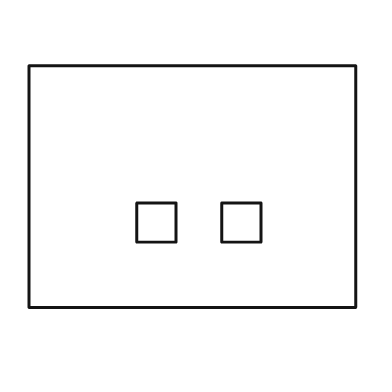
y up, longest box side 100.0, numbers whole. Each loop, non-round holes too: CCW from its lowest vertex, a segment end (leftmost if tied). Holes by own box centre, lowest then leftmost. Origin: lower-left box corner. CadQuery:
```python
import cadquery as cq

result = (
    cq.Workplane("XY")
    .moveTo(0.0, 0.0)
    .lineTo(100.0, 0.0)
    .lineTo(100.0, 74.0)
    .lineTo(0.0, 74.0)
    .close()
    .moveTo(33.0, 20.0)
    .lineTo(45.0, 20.0)
    .lineTo(45.0, 32.0)
    .lineTo(33.0, 32.0)
    .close()
    .moveTo(59.0, 20.0)
    .lineTo(71.0, 20.0)
    .lineTo(71.0, 32.0)
    .lineTo(59.0, 32.0)
    .close()
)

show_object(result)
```